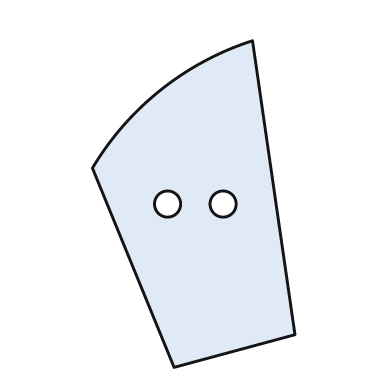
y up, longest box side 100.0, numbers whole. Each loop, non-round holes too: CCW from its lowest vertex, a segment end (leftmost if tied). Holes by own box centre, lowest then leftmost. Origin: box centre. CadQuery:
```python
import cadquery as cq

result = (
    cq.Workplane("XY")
    .moveTo(-6.0, -50.0)
    .lineTo(31.0, -40.0)
    .lineTo(18.0, 50.0)
    .threePointArc((-10.0, 35.0), (-31.0, 11.0))
    .close()
    .moveTo(-8.0, 0.0)
    .circle(4.0)
    .moveTo(9.0, 0.0)
    .circle(4.0)
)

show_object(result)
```